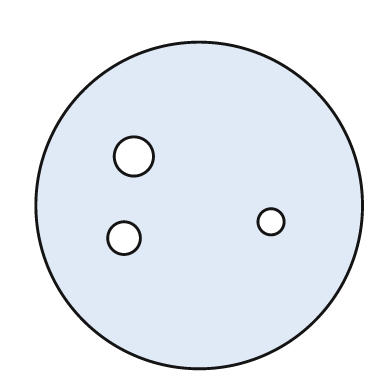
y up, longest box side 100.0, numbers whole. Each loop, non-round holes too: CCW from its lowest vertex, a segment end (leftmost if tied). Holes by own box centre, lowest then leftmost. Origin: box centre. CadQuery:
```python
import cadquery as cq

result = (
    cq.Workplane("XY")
    .moveTo(0.0, 0.0)
    .circle(50.0)
    .moveTo(-23.0, -10.0)
    .circle(5.0)
    .moveTo(22.0, -5.0)
    .circle(4.0)
    .moveTo(-20.0, 15.0)
    .circle(6.0)
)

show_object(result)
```